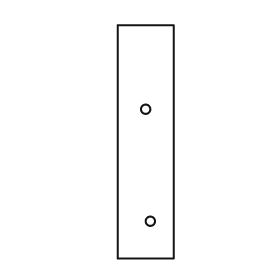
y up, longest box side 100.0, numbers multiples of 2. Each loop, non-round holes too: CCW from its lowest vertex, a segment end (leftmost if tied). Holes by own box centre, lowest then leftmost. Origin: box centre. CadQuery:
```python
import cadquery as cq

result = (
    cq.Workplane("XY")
    .moveTo(-12.0, -50.0)
    .lineTo(12.0, -50.0)
    .lineTo(12.0, 50.0)
    .lineTo(-12.0, 50.0)
    .close()
    .moveTo(2.0, -34.0)
    .circle(2.0)
    .moveTo(0.0, 14.0)
    .circle(2.0)
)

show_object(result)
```